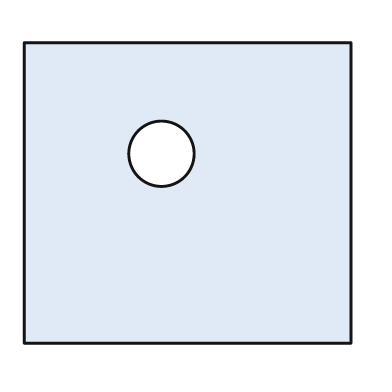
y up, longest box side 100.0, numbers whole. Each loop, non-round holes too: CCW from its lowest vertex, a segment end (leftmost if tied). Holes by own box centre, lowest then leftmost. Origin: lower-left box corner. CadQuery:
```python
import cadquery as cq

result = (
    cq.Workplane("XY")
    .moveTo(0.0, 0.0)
    .lineTo(100.0, 0.0)
    .lineTo(100.0, 92.0)
    .lineTo(0.0, 92.0)
    .close()
    .moveTo(42.0, 58.0)
    .circle(10.0)
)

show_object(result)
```